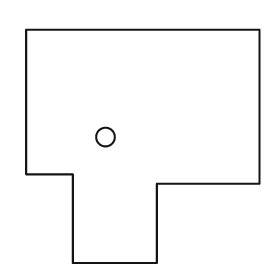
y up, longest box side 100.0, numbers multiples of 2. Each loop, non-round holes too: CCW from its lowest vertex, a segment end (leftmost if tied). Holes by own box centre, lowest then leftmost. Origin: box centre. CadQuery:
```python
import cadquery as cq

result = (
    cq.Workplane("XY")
    .moveTo(-30.0, -50.0)
    .lineTo(6.0, -50.0)
    .lineTo(6.0, -16.0)
    .lineTo(50.0, -16.0)
    .lineTo(50.0, 50.0)
    .lineTo(-50.0, 50.0)
    .lineTo(-50.0, -12.0)
    .lineTo(-30.0, -12.0)
    .close()
    .moveTo(-16.0, 4.0)
    .circle(4.0)
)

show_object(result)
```